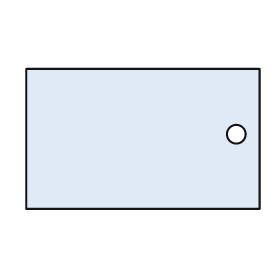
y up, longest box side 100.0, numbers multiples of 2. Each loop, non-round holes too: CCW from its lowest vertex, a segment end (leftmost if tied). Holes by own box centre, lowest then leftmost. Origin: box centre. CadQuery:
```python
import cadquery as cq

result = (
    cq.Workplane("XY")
    .moveTo(-50.0, -30.0)
    .lineTo(50.0, -30.0)
    .lineTo(50.0, 30.0)
    .lineTo(-50.0, 30.0)
    .close()
    .moveTo(40.0, 2.0)
    .circle(4.0)
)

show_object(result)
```